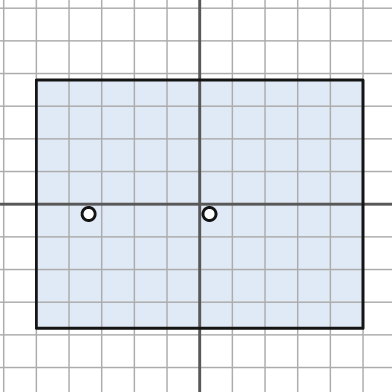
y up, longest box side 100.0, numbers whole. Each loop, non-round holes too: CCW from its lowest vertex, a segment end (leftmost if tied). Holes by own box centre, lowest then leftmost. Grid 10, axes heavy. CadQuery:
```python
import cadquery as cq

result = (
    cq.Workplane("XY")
    .moveTo(-50.0, -38.0)
    .lineTo(50.0, -38.0)
    .lineTo(50.0, 38.0)
    .lineTo(-50.0, 38.0)
    .close()
    .moveTo(-34.0, -3.0)
    .circle(2.0)
    .moveTo(3.0, -3.0)
    .circle(2.0)
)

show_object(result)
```